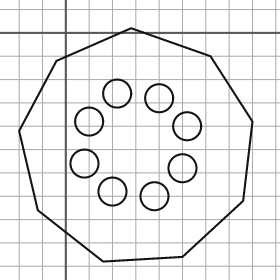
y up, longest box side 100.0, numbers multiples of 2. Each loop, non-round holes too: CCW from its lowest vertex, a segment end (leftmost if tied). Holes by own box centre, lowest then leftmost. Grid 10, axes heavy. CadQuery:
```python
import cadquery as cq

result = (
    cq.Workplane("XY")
    .moveTo(16.0, -98.0)
    .lineTo(50.0, -96.0)
    .lineTo(76.0, -72.0)
    .lineTo(80.0, -38.0)
    .lineTo(62.0, -10.0)
    .lineTo(28.0, 2.0)
    .lineTo(-4.0, -12.0)
    .lineTo(-20.0, -42.0)
    .lineTo(-12.0, -76.0)
    .close()
    .moveTo(38.0, -70.0)
    .circle(6.0)
    .moveTo(20.0, -68.0)
    .circle(6.0)
    .moveTo(50.0, -58.0)
    .circle(6.0)
    .moveTo(8.0, -56.0)
    .circle(6.0)
    .moveTo(52.0, -40.0)
    .circle(6.0)
    .moveTo(10.0, -38.0)
    .circle(6.0)
    .moveTo(40.0, -28.0)
    .circle(6.0)
    .moveTo(22.0, -26.0)
    .circle(6.0)
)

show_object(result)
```